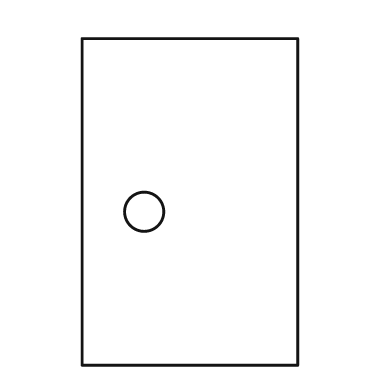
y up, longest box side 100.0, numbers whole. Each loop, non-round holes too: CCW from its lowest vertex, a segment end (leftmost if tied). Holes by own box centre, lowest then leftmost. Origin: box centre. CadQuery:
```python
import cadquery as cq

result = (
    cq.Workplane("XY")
    .moveTo(-33.0, -50.0)
    .lineTo(33.0, -50.0)
    .lineTo(33.0, 50.0)
    .lineTo(-33.0, 50.0)
    .close()
    .moveTo(-14.0, -3.0)
    .circle(6.0)
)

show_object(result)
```